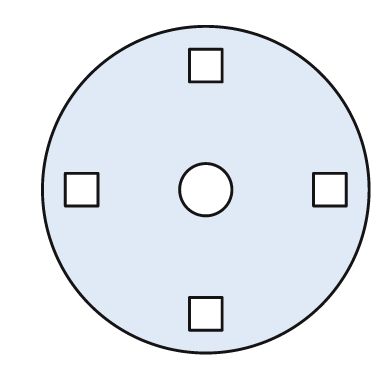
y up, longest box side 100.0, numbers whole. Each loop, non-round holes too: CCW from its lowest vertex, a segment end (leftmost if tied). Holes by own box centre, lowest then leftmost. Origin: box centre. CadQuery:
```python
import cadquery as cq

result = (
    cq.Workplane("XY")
    .moveTo(0.0, 0.0)
    .circle(50.0)
    .moveTo(-5.0, -43.0)
    .lineTo(5.0, -43.0)
    .lineTo(5.0, -33.0)
    .lineTo(-5.0, -33.0)
    .close()
    .moveTo(-43.0, -5.0)
    .lineTo(-33.0, -5.0)
    .lineTo(-33.0, 5.0)
    .lineTo(-43.0, 5.0)
    .close()
    .moveTo(0.0, 0.0)
    .circle(8.0)
    .moveTo(33.0, -5.0)
    .lineTo(43.0, -5.0)
    .lineTo(43.0, 5.0)
    .lineTo(33.0, 5.0)
    .close()
    .moveTo(-5.0, 33.0)
    .lineTo(5.0, 33.0)
    .lineTo(5.0, 43.0)
    .lineTo(-5.0, 43.0)
    .close()
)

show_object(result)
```